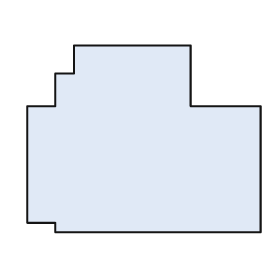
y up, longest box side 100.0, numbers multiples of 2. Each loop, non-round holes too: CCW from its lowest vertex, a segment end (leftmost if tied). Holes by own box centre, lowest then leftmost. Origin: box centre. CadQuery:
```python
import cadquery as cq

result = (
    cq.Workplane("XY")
    .moveTo(-38.0, -40.0)
    .lineTo(50.0, -40.0)
    .lineTo(50.0, 14.0)
    .lineTo(20.0, 14.0)
    .lineTo(20.0, 40.0)
    .lineTo(-30.0, 40.0)
    .lineTo(-30.0, 28.0)
    .lineTo(-38.0, 28.0)
    .lineTo(-38.0, 14.0)
    .lineTo(-50.0, 14.0)
    .lineTo(-50.0, -36.0)
    .lineTo(-38.0, -36.0)
    .close()
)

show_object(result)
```